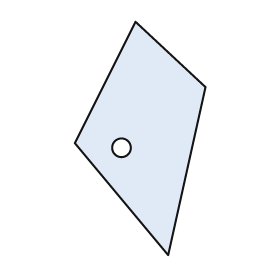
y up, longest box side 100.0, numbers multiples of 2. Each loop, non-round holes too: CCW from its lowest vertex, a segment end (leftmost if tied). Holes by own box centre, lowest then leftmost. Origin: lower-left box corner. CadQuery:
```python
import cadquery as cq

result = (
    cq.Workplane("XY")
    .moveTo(40.0, 0.0)
    .lineTo(56.0, 72.0)
    .lineTo(26.0, 100.0)
    .lineTo(0.0, 48.0)
    .close()
    .moveTo(20.0, 46.0)
    .circle(4.0)
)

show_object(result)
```